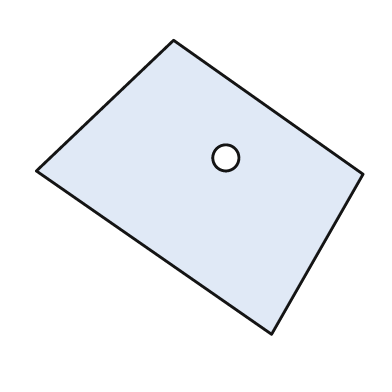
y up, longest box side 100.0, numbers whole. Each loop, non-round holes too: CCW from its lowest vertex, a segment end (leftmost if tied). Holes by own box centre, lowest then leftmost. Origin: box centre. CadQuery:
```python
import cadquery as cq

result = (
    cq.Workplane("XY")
    .moveTo(22.0, -45.0)
    .lineTo(50.0, 4.0)
    .lineTo(-8.0, 45.0)
    .lineTo(-50.0, 5.0)
    .close()
    .moveTo(8.0, 9.0)
    .circle(4.0)
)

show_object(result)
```